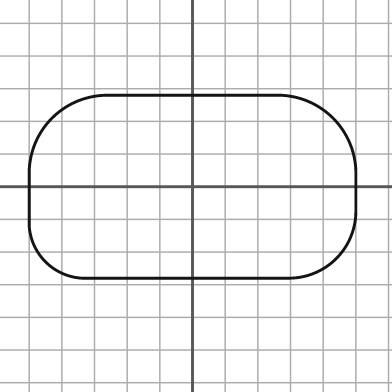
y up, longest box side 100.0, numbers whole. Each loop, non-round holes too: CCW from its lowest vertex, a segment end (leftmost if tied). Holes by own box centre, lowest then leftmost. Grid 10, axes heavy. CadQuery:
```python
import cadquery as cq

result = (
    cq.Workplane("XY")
    .moveTo(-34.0, -28.0)
    .lineTo(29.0, -28.0)
    .threePointArc((44.0, -22.0), (50.0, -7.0))
    .lineTo(50.0, 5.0)
    .threePointArc((43.0, 21.0), (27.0, 28.0))
    .lineTo(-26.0, 28.0)
    .threePointArc((-43.0, 21.0), (-50.0, 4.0))
    .lineTo(-50.0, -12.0)
    .threePointArc((-45.0, -23.0), (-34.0, -28.0))
    .close()
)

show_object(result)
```